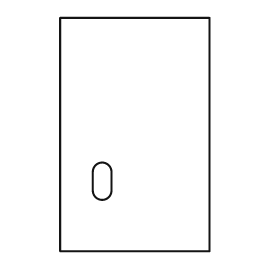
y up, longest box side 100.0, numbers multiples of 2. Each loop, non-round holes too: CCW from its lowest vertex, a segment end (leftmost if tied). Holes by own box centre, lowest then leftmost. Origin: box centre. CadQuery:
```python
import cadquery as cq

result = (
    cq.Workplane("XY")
    .moveTo(-32.0, -50.0)
    .lineTo(32.0, -50.0)
    .lineTo(32.0, 50.0)
    .lineTo(-32.0, 50.0)
    .close()
    .moveTo(-18.0, -24.0)
    .threePointArc((-14.0, -28.0), (-10.0, -24.0))
    .lineTo(-10.0, -16.0)
    .threePointArc((-14.0, -12.0), (-18.0, -16.0))
    .close()
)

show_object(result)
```